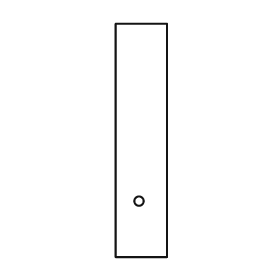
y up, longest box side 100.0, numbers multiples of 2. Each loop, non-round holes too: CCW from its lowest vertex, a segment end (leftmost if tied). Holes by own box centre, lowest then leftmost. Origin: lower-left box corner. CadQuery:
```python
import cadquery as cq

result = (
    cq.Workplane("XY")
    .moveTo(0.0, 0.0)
    .lineTo(22.0, 0.0)
    .lineTo(22.0, 100.0)
    .lineTo(0.0, 100.0)
    .close()
    .moveTo(10.0, 24.0)
    .circle(2.0)
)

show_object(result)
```